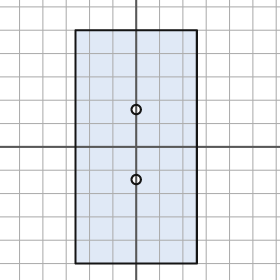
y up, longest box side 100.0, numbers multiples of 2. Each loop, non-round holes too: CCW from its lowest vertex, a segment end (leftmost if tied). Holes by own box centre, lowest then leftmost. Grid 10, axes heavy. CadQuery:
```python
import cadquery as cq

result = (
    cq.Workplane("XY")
    .moveTo(-26.0, -50.0)
    .lineTo(26.0, -50.0)
    .lineTo(26.0, 50.0)
    .lineTo(-26.0, 50.0)
    .close()
    .moveTo(0.0, -14.0)
    .circle(2.0)
    .moveTo(0.0, 16.0)
    .circle(2.0)
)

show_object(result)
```